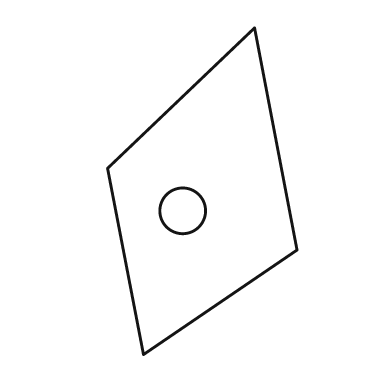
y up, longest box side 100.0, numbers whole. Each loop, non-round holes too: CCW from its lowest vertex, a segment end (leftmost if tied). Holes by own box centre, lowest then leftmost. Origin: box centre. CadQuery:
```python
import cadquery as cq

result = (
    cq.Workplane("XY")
    .moveTo(-18.0, -50.0)
    .lineTo(29.0, -18.0)
    .lineTo(16.0, 50.0)
    .lineTo(-29.0, 7.0)
    .close()
    .moveTo(-6.0, -6.0)
    .circle(7.0)
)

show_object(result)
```